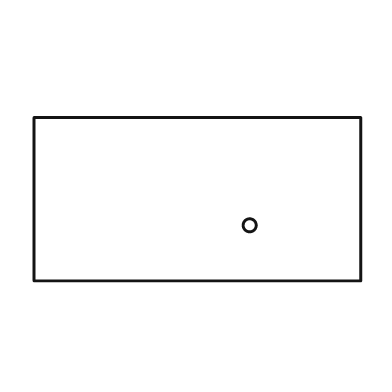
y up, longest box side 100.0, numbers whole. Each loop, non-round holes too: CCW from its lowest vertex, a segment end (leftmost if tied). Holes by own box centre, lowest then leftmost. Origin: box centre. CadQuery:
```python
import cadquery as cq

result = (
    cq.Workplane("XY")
    .moveTo(-50.0, -25.0)
    .lineTo(50.0, -25.0)
    .lineTo(50.0, 25.0)
    .lineTo(-50.0, 25.0)
    .close()
    .moveTo(16.0, -8.0)
    .circle(2.0)
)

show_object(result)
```